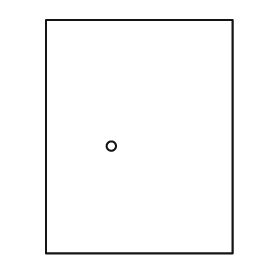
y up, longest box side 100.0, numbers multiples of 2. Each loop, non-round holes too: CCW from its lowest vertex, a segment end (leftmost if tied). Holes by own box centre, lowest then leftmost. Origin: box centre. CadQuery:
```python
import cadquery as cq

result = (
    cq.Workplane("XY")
    .moveTo(-40.0, -50.0)
    .lineTo(40.0, -50.0)
    .lineTo(40.0, 50.0)
    .lineTo(-40.0, 50.0)
    .close()
    .moveTo(-12.0, -4.0)
    .circle(2.0)
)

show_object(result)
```